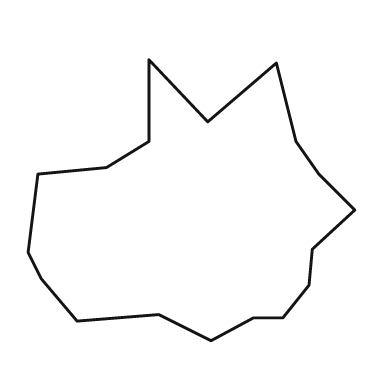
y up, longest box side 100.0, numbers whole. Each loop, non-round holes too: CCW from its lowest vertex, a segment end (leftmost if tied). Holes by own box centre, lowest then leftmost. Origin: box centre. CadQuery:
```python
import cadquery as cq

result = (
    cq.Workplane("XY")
    .moveTo(6.0, -43.0)
    .lineTo(19.0, -36.0)
    .lineTo(28.0, -36.0)
    .lineTo(36.0, -26.0)
    .lineTo(37.0, -15.0)
    .lineTo(50.0, -3.0)
    .lineTo(39.0, 8.0)
    .lineTo(32.0, 18.0)
    .lineTo(26.0, 42.0)
    .lineTo(5.0, 24.0)
    .lineTo(-13.0, 43.0)
    .lineTo(-13.0, 18.0)
    .lineTo(-26.0, 10.0)
    .lineTo(-47.0, 8.0)
    .lineTo(-50.0, -16.0)
    .lineTo(-46.0, -24.0)
    .lineTo(-35.0, -37.0)
    .lineTo(-10.0, -35.0)
    .close()
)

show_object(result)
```